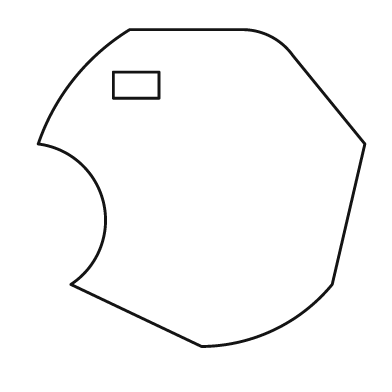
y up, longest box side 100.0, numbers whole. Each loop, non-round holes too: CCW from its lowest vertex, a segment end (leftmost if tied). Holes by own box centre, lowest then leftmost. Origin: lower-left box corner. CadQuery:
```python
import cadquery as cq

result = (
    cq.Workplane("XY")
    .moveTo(50.0, 0.0)
    .threePointArc((72.0, 5.0), (90.0, 19.0))
    .lineTo(100.0, 62.0)
    .lineTo(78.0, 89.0)
    .threePointArc((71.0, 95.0), (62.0, 97.0))
    .lineTo(28.0, 97.0)
    .threePointArc((11.0, 82.0), (0.0, 62.0))
    .threePointArc((20.0, 44.0), (10.0, 19.0))
    .close()
    .moveTo(23.0, 76.0)
    .lineTo(37.0, 76.0)
    .lineTo(37.0, 84.0)
    .lineTo(23.0, 84.0)
    .close()
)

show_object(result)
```